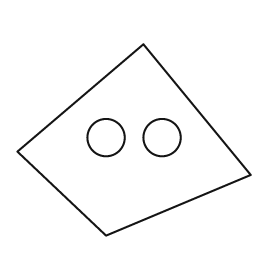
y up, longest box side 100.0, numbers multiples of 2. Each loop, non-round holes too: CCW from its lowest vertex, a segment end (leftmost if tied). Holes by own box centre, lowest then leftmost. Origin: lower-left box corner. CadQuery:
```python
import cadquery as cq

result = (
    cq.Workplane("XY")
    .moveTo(38.0, 0.0)
    .lineTo(100.0, 26.0)
    .lineTo(54.0, 82.0)
    .lineTo(0.0, 36.0)
    .close()
    .moveTo(38.0, 42.0)
    .circle(8.0)
    .moveTo(62.0, 42.0)
    .circle(8.0)
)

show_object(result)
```